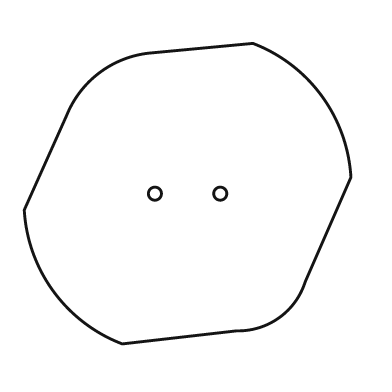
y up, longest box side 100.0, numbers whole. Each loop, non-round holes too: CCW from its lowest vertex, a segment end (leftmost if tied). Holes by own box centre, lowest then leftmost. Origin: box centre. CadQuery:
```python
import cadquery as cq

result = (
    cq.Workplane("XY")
    .moveTo(-20.0, -46.0)
    .lineTo(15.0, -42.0)
    .threePointArc((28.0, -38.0), (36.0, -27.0))
    .lineTo(50.0, 5.0)
    .threePointArc((41.0, 30.0), (20.0, 46.0))
    .lineTo(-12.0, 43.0)
    .threePointArc((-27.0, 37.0), (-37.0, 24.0))
    .lineTo(-50.0, -5.0)
    .threePointArc((-41.0, -30.0), (-20.0, -46.0))
    .close()
    .moveTo(-10.0, 0.0)
    .circle(2.0)
    .moveTo(10.0, 0.0)
    .circle(2.0)
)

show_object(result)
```